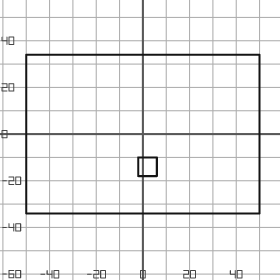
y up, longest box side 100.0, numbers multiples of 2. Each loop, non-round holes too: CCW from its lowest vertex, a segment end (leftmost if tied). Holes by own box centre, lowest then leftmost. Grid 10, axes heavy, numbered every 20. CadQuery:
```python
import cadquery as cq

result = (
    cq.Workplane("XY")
    .moveTo(-50.0, -34.0)
    .lineTo(50.0, -34.0)
    .lineTo(50.0, 34.0)
    .lineTo(-50.0, 34.0)
    .close()
    .moveTo(-2.0, -18.0)
    .lineTo(6.0, -18.0)
    .lineTo(6.0, -10.0)
    .lineTo(-2.0, -10.0)
    .close()
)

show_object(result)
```